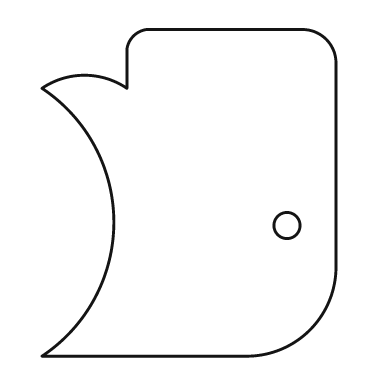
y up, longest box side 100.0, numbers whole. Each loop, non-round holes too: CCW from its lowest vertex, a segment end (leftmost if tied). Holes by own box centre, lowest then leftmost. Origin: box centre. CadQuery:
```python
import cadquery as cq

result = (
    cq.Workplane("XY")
    .moveTo(-45.0, -50.0)
    .lineTo(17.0, -50.0)
    .threePointArc((37.0, -42.0), (45.0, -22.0))
    .lineTo(45.0, 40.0)
    .threePointArc((42.0, 47.0), (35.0, 50.0))
    .lineTo(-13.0, 50.0)
    .threePointArc((-17.0, 48.0), (-19.0, 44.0))
    .lineTo(-19.0, 32.0)
    .threePointArc((-32.0, 36.0), (-45.0, 32.0))
    .threePointArc((-23.0, -9.0), (-45.0, -50.0))
    .close()
    .moveTo(30.0, -10.0)
    .circle(4.0)
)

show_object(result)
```